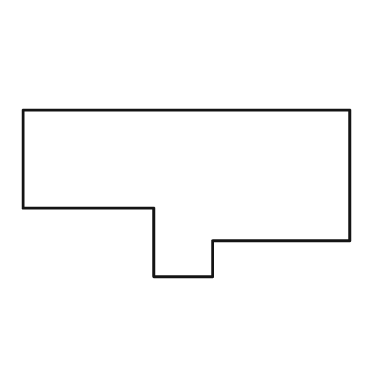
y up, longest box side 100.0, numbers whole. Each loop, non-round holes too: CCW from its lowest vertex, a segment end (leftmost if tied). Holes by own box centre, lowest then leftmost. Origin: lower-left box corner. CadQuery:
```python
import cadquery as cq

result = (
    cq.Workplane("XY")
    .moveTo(40.0, 0.0)
    .lineTo(58.0, 0.0)
    .lineTo(58.0, 11.0)
    .lineTo(100.0, 11.0)
    .lineTo(100.0, 51.0)
    .lineTo(0.0, 51.0)
    .lineTo(0.0, 21.0)
    .lineTo(40.0, 21.0)
    .close()
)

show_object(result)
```